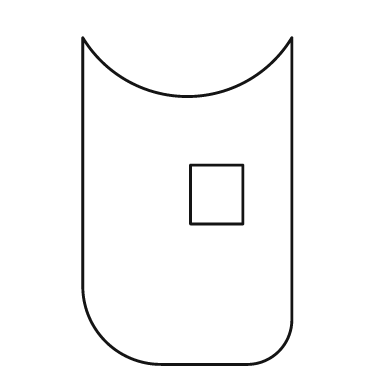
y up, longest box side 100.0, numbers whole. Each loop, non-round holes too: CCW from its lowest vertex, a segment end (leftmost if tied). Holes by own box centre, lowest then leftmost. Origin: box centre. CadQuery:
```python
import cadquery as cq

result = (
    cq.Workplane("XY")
    .moveTo(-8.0, -50.0)
    .lineTo(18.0, -50.0)
    .threePointArc((28.0, -46.0), (32.0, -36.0))
    .lineTo(32.0, 50.0)
    .threePointArc((0.0, 32.0), (-32.0, 50.0))
    .lineTo(-32.0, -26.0)
    .threePointArc((-25.0, -43.0), (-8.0, -50.0))
    .close()
    .moveTo(1.0, -7.0)
    .lineTo(17.0, -7.0)
    .lineTo(17.0, 11.0)
    .lineTo(1.0, 11.0)
    .close()
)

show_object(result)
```